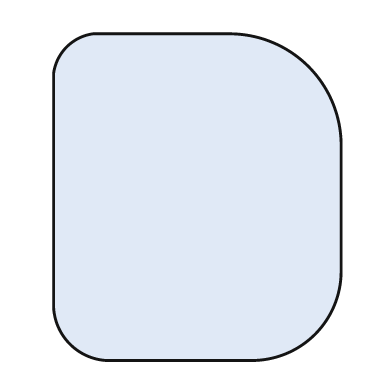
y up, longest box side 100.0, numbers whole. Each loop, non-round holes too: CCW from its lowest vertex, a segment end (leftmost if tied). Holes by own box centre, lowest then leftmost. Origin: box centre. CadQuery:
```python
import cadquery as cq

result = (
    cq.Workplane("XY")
    .moveTo(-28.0, -50.0)
    .lineTo(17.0, -50.0)
    .threePointArc((36.0, -42.0), (44.0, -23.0))
    .lineTo(44.0, 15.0)
    .threePointArc((34.0, 40.0), (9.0, 50.0))
    .lineTo(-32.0, 50.0)
    .threePointArc((-40.0, 46.0), (-44.0, 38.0))
    .lineTo(-44.0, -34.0)
    .threePointArc((-39.0, -45.0), (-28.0, -50.0))
    .close()
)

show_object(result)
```